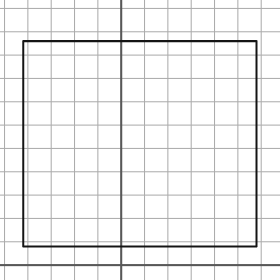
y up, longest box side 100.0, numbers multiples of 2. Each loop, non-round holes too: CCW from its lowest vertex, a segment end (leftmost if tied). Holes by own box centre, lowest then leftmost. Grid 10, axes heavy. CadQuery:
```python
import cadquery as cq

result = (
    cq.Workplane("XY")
    .moveTo(-42.0, 8.0)
    .lineTo(58.0, 8.0)
    .lineTo(58.0, 96.0)
    .lineTo(-42.0, 96.0)
    .close()
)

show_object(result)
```